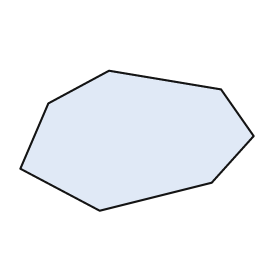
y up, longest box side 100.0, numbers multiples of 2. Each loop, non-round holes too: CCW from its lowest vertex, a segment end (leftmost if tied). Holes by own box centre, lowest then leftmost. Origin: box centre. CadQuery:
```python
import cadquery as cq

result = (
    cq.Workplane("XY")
    .moveTo(-16.0, -30.0)
    .lineTo(32.0, -18.0)
    .lineTo(50.0, 2.0)
    .lineTo(36.0, 22.0)
    .lineTo(-12.0, 30.0)
    .lineTo(-38.0, 16.0)
    .lineTo(-50.0, -12.0)
    .close()
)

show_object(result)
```